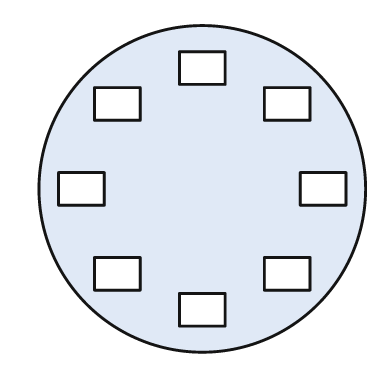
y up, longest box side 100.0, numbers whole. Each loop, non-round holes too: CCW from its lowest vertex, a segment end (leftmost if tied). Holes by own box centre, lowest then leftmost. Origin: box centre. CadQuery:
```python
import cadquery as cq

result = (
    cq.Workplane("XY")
    .moveTo(0.0, 0.0)
    .circle(50.0)
    .moveTo(-7.0, -42.0)
    .lineTo(7.0, -42.0)
    .lineTo(7.0, -32.0)
    .lineTo(-7.0, -32.0)
    .close()
    .moveTo(-33.0, -31.0)
    .lineTo(-19.0, -31.0)
    .lineTo(-19.0, -21.0)
    .lineTo(-33.0, -21.0)
    .close()
    .moveTo(19.0, -31.0)
    .lineTo(33.0, -31.0)
    .lineTo(33.0, -21.0)
    .lineTo(19.0, -21.0)
    .close()
    .moveTo(-44.0, -5.0)
    .lineTo(-30.0, -5.0)
    .lineTo(-30.0, 5.0)
    .lineTo(-44.0, 5.0)
    .close()
    .moveTo(30.0, -5.0)
    .lineTo(44.0, -5.0)
    .lineTo(44.0, 5.0)
    .lineTo(30.0, 5.0)
    .close()
    .moveTo(-33.0, 21.0)
    .lineTo(-19.0, 21.0)
    .lineTo(-19.0, 31.0)
    .lineTo(-33.0, 31.0)
    .close()
    .moveTo(19.0, 21.0)
    .lineTo(33.0, 21.0)
    .lineTo(33.0, 31.0)
    .lineTo(19.0, 31.0)
    .close()
    .moveTo(-7.0, 32.0)
    .lineTo(7.0, 32.0)
    .lineTo(7.0, 42.0)
    .lineTo(-7.0, 42.0)
    .close()
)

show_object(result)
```